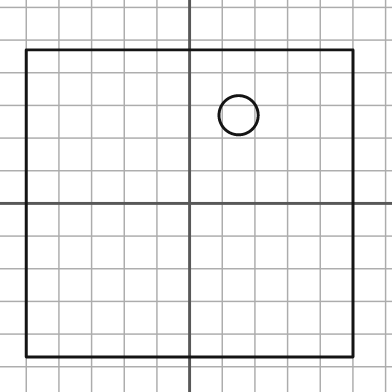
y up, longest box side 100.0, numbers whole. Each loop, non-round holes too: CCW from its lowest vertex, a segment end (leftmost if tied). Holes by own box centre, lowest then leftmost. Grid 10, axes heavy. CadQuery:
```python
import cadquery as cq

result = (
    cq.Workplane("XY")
    .moveTo(-50.0, -47.0)
    .lineTo(50.0, -47.0)
    .lineTo(50.0, 47.0)
    .lineTo(-50.0, 47.0)
    .close()
    .moveTo(15.0, 27.0)
    .circle(6.0)
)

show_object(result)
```